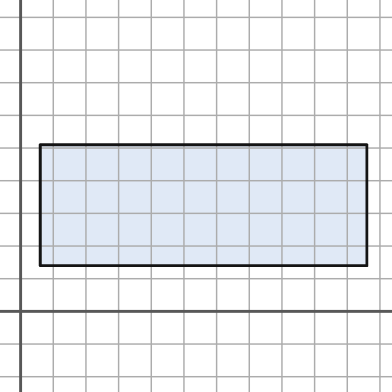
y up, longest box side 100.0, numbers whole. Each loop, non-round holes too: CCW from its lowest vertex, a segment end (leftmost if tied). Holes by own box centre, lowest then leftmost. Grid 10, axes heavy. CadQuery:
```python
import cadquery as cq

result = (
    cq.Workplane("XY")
    .moveTo(6.0, 14.0)
    .lineTo(106.0, 14.0)
    .lineTo(106.0, 51.0)
    .lineTo(6.0, 51.0)
    .close()
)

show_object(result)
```